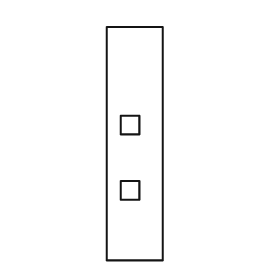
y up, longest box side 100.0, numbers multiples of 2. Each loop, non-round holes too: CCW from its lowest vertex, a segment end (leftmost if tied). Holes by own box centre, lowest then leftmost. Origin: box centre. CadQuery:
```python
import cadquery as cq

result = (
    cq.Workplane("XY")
    .moveTo(-12.0, -50.0)
    .lineTo(12.0, -50.0)
    .lineTo(12.0, 50.0)
    .lineTo(-12.0, 50.0)
    .close()
    .moveTo(-6.0, -24.0)
    .lineTo(2.0, -24.0)
    .lineTo(2.0, -16.0)
    .lineTo(-6.0, -16.0)
    .close()
    .moveTo(-6.0, 4.0)
    .lineTo(2.0, 4.0)
    .lineTo(2.0, 12.0)
    .lineTo(-6.0, 12.0)
    .close()
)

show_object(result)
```